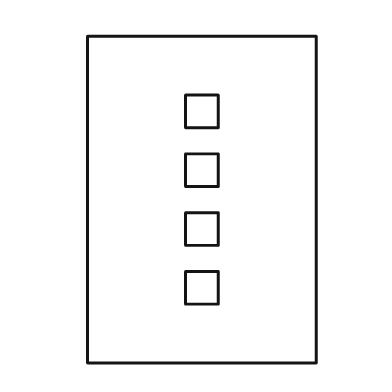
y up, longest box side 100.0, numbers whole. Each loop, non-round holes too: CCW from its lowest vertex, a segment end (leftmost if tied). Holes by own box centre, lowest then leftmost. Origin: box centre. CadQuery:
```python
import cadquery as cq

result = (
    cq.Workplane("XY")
    .moveTo(-35.0, -50.0)
    .lineTo(35.0, -50.0)
    .lineTo(35.0, 50.0)
    .lineTo(-35.0, 50.0)
    .close()
    .moveTo(-5.0, -32.0)
    .lineTo(5.0, -32.0)
    .lineTo(5.0, -22.0)
    .lineTo(-5.0, -22.0)
    .close()
    .moveTo(-5.0, -14.0)
    .lineTo(5.0, -14.0)
    .lineTo(5.0, -4.0)
    .lineTo(-5.0, -4.0)
    .close()
    .moveTo(-5.0, 4.0)
    .lineTo(5.0, 4.0)
    .lineTo(5.0, 14.0)
    .lineTo(-5.0, 14.0)
    .close()
    .moveTo(-5.0, 22.0)
    .lineTo(5.0, 22.0)
    .lineTo(5.0, 32.0)
    .lineTo(-5.0, 32.0)
    .close()
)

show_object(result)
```